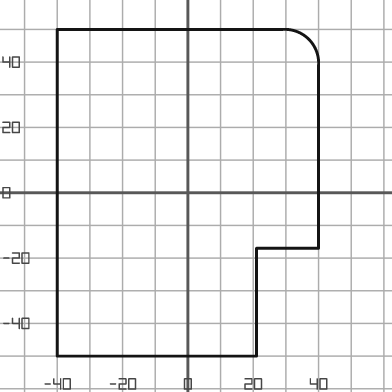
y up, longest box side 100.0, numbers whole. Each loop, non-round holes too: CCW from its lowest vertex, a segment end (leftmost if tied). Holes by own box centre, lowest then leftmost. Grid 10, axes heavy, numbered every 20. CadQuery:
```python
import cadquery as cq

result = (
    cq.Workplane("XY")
    .moveTo(-40.0, -50.0)
    .lineTo(21.0, -50.0)
    .lineTo(21.0, -17.0)
    .lineTo(40.0, -17.0)
    .lineTo(40.0, 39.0)
    .threePointArc((37.0, 47.0), (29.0, 50.0))
    .lineTo(-40.0, 50.0)
    .close()
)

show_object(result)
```